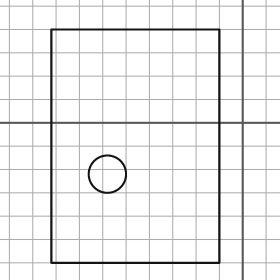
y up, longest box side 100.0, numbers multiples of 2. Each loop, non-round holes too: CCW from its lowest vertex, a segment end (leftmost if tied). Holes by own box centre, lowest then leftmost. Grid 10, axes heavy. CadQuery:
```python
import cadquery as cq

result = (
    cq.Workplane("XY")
    .moveTo(-82.0, -60.0)
    .lineTo(-10.0, -60.0)
    .lineTo(-10.0, 40.0)
    .lineTo(-82.0, 40.0)
    .close()
    .moveTo(-58.0, -22.0)
    .circle(8.0)
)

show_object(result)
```